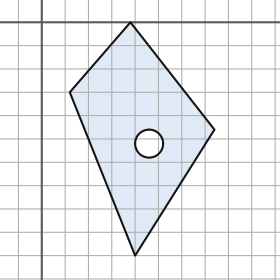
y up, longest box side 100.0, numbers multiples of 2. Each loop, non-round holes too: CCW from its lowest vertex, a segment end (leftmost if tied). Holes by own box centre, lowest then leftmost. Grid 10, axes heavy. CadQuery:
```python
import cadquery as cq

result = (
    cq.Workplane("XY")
    .moveTo(40.0, -100.0)
    .lineTo(74.0, -46.0)
    .lineTo(38.0, 0.0)
    .lineTo(12.0, -30.0)
    .close()
    .moveTo(46.0, -52.0)
    .circle(6.0)
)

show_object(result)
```